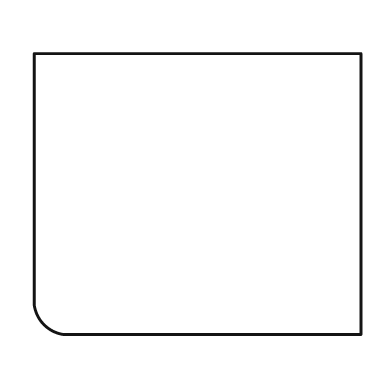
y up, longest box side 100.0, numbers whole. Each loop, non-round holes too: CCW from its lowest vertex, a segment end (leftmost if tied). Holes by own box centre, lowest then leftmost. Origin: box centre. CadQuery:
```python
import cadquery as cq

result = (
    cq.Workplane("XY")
    .moveTo(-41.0, -43.0)
    .lineTo(50.0, -43.0)
    .lineTo(50.0, 43.0)
    .lineTo(-50.0, 43.0)
    .lineTo(-50.0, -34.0)
    .threePointArc((-47.0, -40.0), (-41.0, -43.0))
    .close()
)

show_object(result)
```